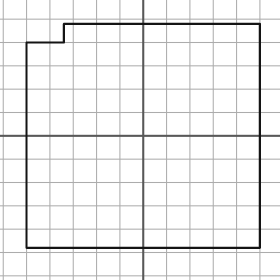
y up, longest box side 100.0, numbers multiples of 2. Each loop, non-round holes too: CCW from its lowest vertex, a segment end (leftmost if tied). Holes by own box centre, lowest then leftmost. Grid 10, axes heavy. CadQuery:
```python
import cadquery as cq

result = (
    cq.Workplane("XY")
    .moveTo(-50.0, -48.0)
    .lineTo(50.0, -48.0)
    .lineTo(50.0, 48.0)
    .lineTo(-34.0, 48.0)
    .lineTo(-34.0, 40.0)
    .lineTo(-50.0, 40.0)
    .close()
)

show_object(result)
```